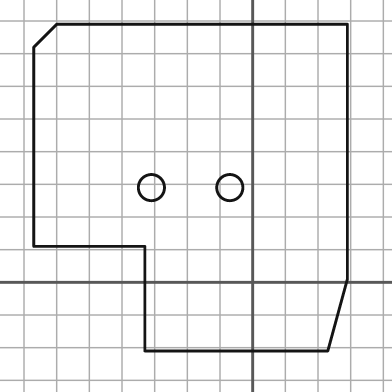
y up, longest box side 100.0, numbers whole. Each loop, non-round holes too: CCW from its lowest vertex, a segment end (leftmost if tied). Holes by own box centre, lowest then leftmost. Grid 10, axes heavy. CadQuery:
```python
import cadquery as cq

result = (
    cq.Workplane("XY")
    .moveTo(-33.0, -21.0)
    .lineTo(23.0, -21.0)
    .lineTo(29.0, 1.0)
    .lineTo(29.0, 79.0)
    .lineTo(-60.0, 79.0)
    .lineTo(-67.0, 72.0)
    .lineTo(-67.0, 11.0)
    .lineTo(-33.0, 11.0)
    .close()
    .moveTo(-31.0, 29.0)
    .circle(4.0)
    .moveTo(-7.0, 29.0)
    .circle(4.0)
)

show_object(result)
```